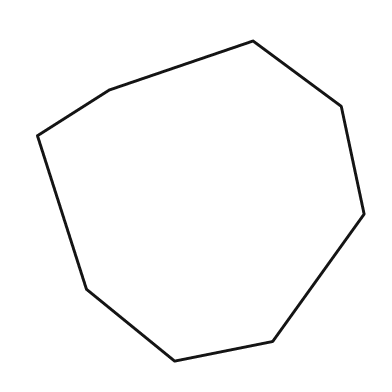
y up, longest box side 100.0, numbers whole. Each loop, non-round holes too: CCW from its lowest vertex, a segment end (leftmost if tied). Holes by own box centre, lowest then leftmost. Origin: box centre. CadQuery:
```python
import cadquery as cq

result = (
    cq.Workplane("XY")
    .moveTo(-8.0, -49.0)
    .lineTo(22.0, -43.0)
    .lineTo(50.0, -4.0)
    .lineTo(43.0, 29.0)
    .lineTo(16.0, 49.0)
    .lineTo(-28.0, 34.0)
    .lineTo(-50.0, 20.0)
    .lineTo(-35.0, -27.0)
    .close()
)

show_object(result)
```